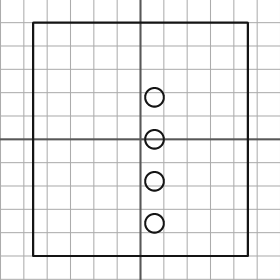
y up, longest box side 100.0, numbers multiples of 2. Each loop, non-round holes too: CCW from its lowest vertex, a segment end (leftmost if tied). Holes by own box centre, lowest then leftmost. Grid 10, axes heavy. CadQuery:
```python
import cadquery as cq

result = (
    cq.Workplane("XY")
    .moveTo(-46.0, -50.0)
    .lineTo(46.0, -50.0)
    .lineTo(46.0, 50.0)
    .lineTo(-46.0, 50.0)
    .close()
    .moveTo(6.0, -36.0)
    .circle(4.0)
    .moveTo(6.0, -18.0)
    .circle(4.0)
    .moveTo(6.0, 0.0)
    .circle(4.0)
    .moveTo(6.0, 18.0)
    .circle(4.0)
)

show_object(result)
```